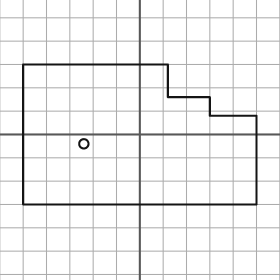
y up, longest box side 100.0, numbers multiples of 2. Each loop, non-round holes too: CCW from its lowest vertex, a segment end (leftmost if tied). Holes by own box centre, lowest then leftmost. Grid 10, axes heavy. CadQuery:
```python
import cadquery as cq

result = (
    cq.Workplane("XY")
    .moveTo(-50.0, -30.0)
    .lineTo(50.0, -30.0)
    .lineTo(50.0, 8.0)
    .lineTo(30.0, 8.0)
    .lineTo(30.0, 16.0)
    .lineTo(12.0, 16.0)
    .lineTo(12.0, 30.0)
    .lineTo(-50.0, 30.0)
    .close()
    .moveTo(-24.0, -4.0)
    .circle(2.0)
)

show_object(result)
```